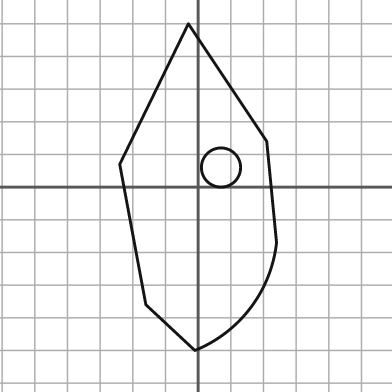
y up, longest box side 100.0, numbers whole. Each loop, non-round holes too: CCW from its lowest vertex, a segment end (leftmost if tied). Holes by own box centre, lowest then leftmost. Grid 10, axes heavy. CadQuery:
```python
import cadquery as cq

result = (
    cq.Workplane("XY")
    .moveTo(-1.0, -50.0)
    .threePointArc((16.0, -37.0), (24.0, -17.0))
    .lineTo(21.0, 14.0)
    .lineTo(-3.0, 50.0)
    .lineTo(-24.0, 7.0)
    .lineTo(-16.0, -36.0)
    .close()
    .moveTo(7.0, 6.0)
    .circle(6.0)
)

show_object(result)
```